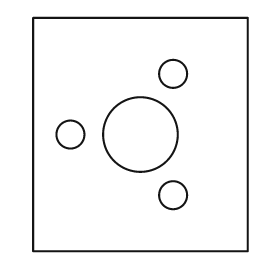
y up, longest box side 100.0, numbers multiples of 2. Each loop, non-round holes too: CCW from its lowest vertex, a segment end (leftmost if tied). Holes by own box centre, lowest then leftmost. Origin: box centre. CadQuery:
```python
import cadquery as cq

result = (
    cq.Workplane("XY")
    .moveTo(-46.0, -50.0)
    .lineTo(46.0, -50.0)
    .lineTo(46.0, 50.0)
    .lineTo(-46.0, 50.0)
    .close()
    .moveTo(14.0, -26.0)
    .circle(6.0)
    .moveTo(-30.0, 0.0)
    .circle(6.0)
    .moveTo(0.0, 0.0)
    .circle(16.0)
    .moveTo(14.0, 26.0)
    .circle(6.0)
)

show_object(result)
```